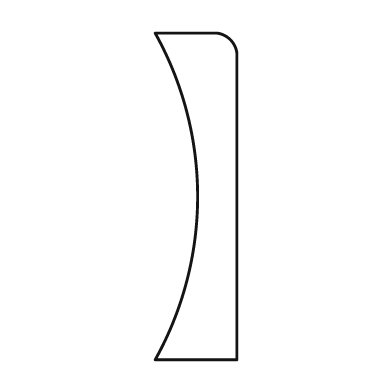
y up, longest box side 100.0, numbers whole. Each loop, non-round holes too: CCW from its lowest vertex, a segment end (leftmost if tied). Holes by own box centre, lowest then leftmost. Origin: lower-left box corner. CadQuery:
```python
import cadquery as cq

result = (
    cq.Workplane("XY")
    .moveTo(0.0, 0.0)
    .lineTo(25.0, 0.0)
    .lineTo(25.0, 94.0)
    .threePointArc((23.0, 98.0), (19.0, 100.0))
    .lineTo(0.0, 100.0)
    .threePointArc((13.0, 50.0), (0.0, 0.0))
    .close()
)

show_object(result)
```